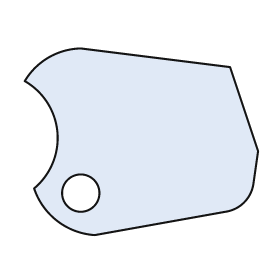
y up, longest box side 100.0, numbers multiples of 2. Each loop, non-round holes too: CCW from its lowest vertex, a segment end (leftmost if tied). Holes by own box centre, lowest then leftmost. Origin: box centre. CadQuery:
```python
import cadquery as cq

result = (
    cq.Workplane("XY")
    .moveTo(-20.0, -40.0)
    .lineTo(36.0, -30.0)
    .threePointArc((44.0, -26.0), (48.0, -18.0))
    .lineTo(50.0, -4.0)
    .lineTo(38.0, 32.0)
    .lineTo(-26.0, 40.0)
    .threePointArc((-40.0, 36.0), (-50.0, 26.0))
    .threePointArc((-36.0, 4.0), (-46.0, -20.0))
    .threePointArc((-36.0, -34.0), (-20.0, -40.0))
    .close()
    .moveTo(-26.0, -22.0)
    .circle(8.0)
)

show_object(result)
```